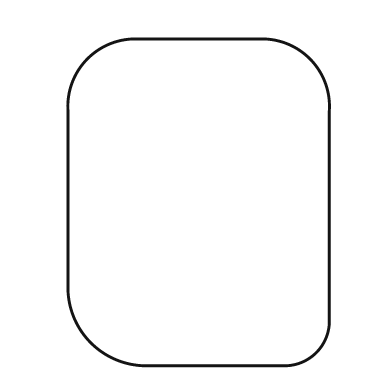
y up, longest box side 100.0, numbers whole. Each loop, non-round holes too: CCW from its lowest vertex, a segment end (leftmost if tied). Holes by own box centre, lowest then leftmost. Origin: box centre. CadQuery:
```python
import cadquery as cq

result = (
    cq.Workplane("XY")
    .moveTo(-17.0, -50.0)
    .lineTo(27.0, -50.0)
    .threePointArc((36.0, -46.0), (40.0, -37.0))
    .lineTo(40.0, 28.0)
    .threePointArc((34.0, 44.0), (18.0, 50.0))
    .lineTo(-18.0, 50.0)
    .threePointArc((-34.0, 44.0), (-40.0, 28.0))
    .lineTo(-40.0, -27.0)
    .threePointArc((-33.0, -43.0), (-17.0, -50.0))
    .close()
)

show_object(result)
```